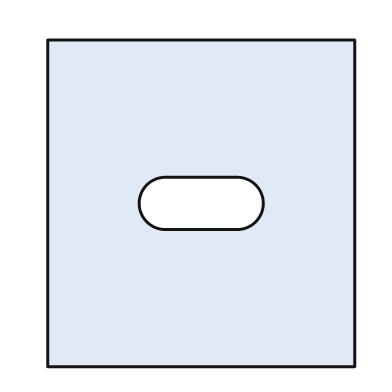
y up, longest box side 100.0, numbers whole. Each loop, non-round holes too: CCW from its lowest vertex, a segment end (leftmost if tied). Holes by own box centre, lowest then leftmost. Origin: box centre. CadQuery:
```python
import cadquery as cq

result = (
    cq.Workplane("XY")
    .moveTo(-47.0, -50.0)
    .lineTo(47.0, -50.0)
    .lineTo(47.0, 50.0)
    .lineTo(-47.0, 50.0)
    .close()
    .moveTo(-11.0, -8.0)
    .lineTo(11.0, -8.0)
    .threePointArc((19.0, 0.0), (11.0, 8.0))
    .lineTo(-11.0, 8.0)
    .threePointArc((-19.0, 0.0), (-11.0, -8.0))
    .close()
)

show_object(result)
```